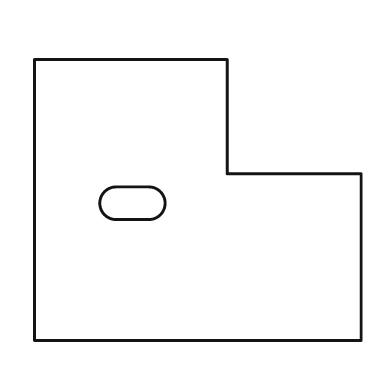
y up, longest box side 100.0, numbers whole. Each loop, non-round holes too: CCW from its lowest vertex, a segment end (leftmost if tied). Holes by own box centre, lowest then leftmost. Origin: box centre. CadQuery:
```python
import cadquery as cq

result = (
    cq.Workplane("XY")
    .moveTo(-50.0, -43.0)
    .lineTo(50.0, -43.0)
    .lineTo(50.0, 8.0)
    .lineTo(9.0, 8.0)
    .lineTo(9.0, 43.0)
    .lineTo(-50.0, 43.0)
    .close()
    .moveTo(-25.0, -6.0)
    .lineTo(-15.0, -6.0)
    .threePointArc((-10.0, -1.0), (-15.0, 4.0))
    .lineTo(-25.0, 4.0)
    .threePointArc((-30.0, -1.0), (-25.0, -6.0))
    .close()
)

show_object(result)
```